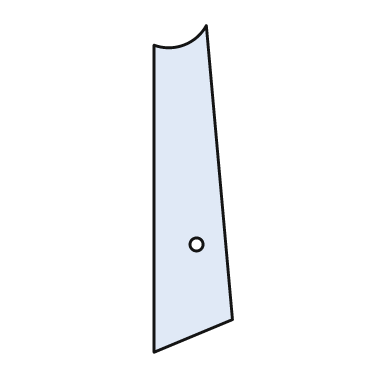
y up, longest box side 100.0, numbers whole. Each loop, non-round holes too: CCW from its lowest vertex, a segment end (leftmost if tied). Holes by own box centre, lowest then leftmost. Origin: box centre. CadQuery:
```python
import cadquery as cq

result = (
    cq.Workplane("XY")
    .moveTo(-12.0, -50.0)
    .lineTo(12.0, -40.0)
    .lineTo(4.0, 50.0)
    .threePointArc((-3.0, 44.0), (-12.0, 44.0))
    .close()
    .moveTo(1.0, -17.0)
    .circle(2.0)
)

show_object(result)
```